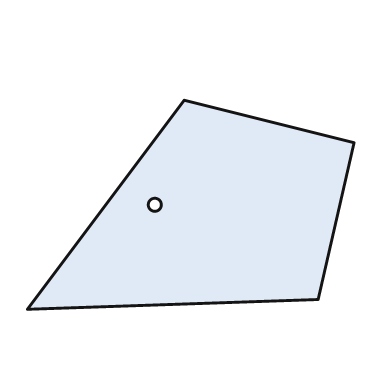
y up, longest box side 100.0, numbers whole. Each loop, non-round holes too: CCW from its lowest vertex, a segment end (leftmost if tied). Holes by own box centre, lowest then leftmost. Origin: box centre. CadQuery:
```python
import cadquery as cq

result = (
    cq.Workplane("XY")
    .moveTo(-50.0, -32.0)
    .lineTo(39.0, -29.0)
    .lineTo(50.0, 19.0)
    .lineTo(-2.0, 32.0)
    .close()
    .moveTo(-11.0, 0.0)
    .circle(2.0)
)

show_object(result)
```